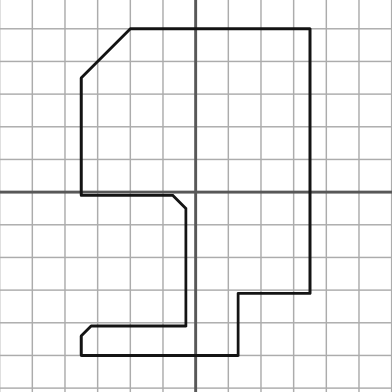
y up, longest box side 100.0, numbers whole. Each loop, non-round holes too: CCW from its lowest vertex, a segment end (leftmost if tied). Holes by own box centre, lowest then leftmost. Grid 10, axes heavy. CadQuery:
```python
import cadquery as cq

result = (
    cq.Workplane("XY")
    .moveTo(-35.0, -50.0)
    .lineTo(13.0, -50.0)
    .lineTo(13.0, -31.0)
    .lineTo(35.0, -31.0)
    .lineTo(35.0, 50.0)
    .lineTo(-20.0, 50.0)
    .lineTo(-35.0, 35.0)
    .lineTo(-35.0, -1.0)
    .lineTo(-7.0, -1.0)
    .lineTo(-3.0, -5.0)
    .lineTo(-3.0, -41.0)
    .lineTo(-32.0, -41.0)
    .lineTo(-35.0, -44.0)
    .close()
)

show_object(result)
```